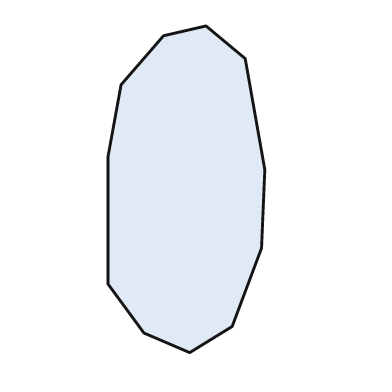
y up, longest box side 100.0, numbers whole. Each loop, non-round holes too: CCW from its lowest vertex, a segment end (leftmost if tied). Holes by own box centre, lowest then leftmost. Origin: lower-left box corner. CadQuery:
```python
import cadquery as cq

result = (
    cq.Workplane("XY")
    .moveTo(25.0, 0.0)
    .lineTo(38.0, 8.0)
    .lineTo(47.0, 32.0)
    .lineTo(48.0, 56.0)
    .lineTo(42.0, 90.0)
    .lineTo(30.0, 100.0)
    .lineTo(17.0, 97.0)
    .lineTo(4.0, 82.0)
    .lineTo(0.0, 60.0)
    .lineTo(0.0, 21.0)
    .lineTo(11.0, 6.0)
    .close()
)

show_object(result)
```